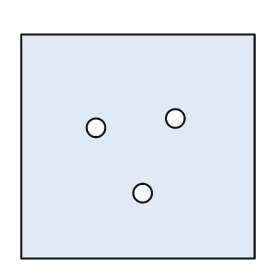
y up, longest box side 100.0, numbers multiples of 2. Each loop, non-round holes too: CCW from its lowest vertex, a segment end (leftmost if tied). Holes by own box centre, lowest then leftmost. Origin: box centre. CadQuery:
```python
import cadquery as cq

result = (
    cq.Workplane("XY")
    .moveTo(-50.0, -48.0)
    .lineTo(50.0, -48.0)
    .lineTo(50.0, 48.0)
    .lineTo(-50.0, 48.0)
    .close()
    .moveTo(2.0, -20.0)
    .circle(4.0)
    .moveTo(-18.0, 8.0)
    .circle(4.0)
    .moveTo(16.0, 12.0)
    .circle(4.0)
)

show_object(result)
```